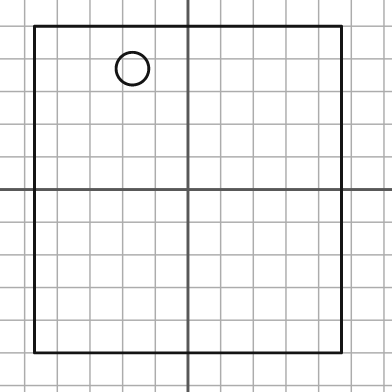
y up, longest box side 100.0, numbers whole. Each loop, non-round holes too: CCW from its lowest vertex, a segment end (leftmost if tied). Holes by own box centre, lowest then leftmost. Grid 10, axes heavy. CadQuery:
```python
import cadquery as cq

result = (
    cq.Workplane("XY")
    .moveTo(-47.0, -50.0)
    .lineTo(47.0, -50.0)
    .lineTo(47.0, 50.0)
    .lineTo(-47.0, 50.0)
    .close()
    .moveTo(-17.0, 37.0)
    .circle(5.0)
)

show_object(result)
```